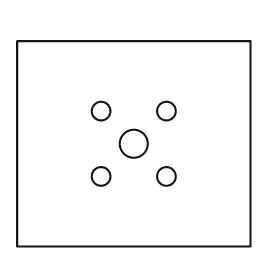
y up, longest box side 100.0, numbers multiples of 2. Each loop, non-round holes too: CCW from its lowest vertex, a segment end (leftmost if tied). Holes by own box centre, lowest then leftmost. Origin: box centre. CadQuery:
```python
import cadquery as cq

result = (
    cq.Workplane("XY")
    .moveTo(-50.0, -44.0)
    .lineTo(50.0, -44.0)
    .lineTo(50.0, 44.0)
    .lineTo(-50.0, 44.0)
    .close()
    .moveTo(-14.0, -14.0)
    .circle(4.0)
    .moveTo(14.0, -14.0)
    .circle(4.0)
    .moveTo(0.0, 0.0)
    .circle(6.0)
    .moveTo(-14.0, 14.0)
    .circle(4.0)
    .moveTo(14.0, 14.0)
    .circle(4.0)
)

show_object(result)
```